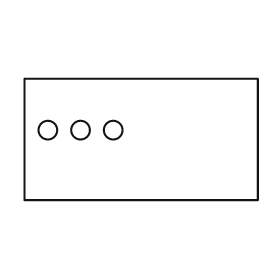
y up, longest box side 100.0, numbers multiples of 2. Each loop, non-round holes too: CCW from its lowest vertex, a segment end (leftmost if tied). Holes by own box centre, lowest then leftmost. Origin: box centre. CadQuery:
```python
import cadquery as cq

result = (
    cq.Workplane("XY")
    .moveTo(-50.0, -26.0)
    .lineTo(50.0, -26.0)
    .lineTo(50.0, 26.0)
    .lineTo(-50.0, 26.0)
    .close()
    .moveTo(-40.0, 4.0)
    .circle(4.0)
    .moveTo(-26.0, 4.0)
    .circle(4.0)
    .moveTo(-12.0, 4.0)
    .circle(4.0)
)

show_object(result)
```